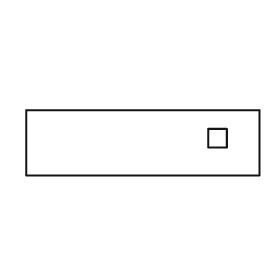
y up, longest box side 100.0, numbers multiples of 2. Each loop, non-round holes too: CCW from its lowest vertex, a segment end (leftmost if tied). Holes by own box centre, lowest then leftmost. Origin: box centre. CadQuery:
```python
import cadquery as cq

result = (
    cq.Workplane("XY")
    .moveTo(-50.0, -14.0)
    .lineTo(50.0, -14.0)
    .lineTo(50.0, 14.0)
    .lineTo(-50.0, 14.0)
    .close()
    .moveTo(28.0, -2.0)
    .lineTo(36.0, -2.0)
    .lineTo(36.0, 6.0)
    .lineTo(28.0, 6.0)
    .close()
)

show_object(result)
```